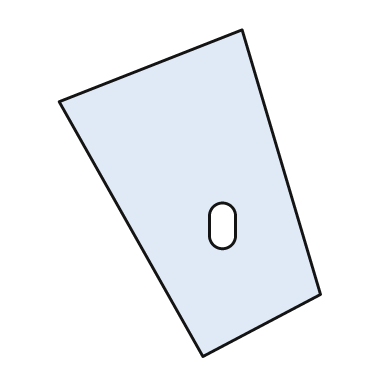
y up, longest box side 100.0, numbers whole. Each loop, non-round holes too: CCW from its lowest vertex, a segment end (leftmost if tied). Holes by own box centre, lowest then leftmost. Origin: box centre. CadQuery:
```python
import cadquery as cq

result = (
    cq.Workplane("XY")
    .moveTo(4.0, -50.0)
    .lineTo(40.0, -31.0)
    .lineTo(16.0, 50.0)
    .lineTo(-40.0, 28.0)
    .close()
    .moveTo(6.0, -13.0)
    .threePointArc((10.0, -17.0), (14.0, -13.0))
    .lineTo(14.0, -7.0)
    .threePointArc((10.0, -3.0), (6.0, -7.0))
    .close()
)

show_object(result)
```